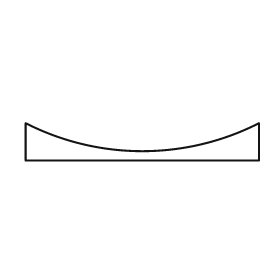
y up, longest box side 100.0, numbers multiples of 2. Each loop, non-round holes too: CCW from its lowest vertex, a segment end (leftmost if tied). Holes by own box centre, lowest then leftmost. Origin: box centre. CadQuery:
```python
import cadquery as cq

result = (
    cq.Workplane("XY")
    .moveTo(-50.0, -8.0)
    .lineTo(50.0, -8.0)
    .lineTo(50.0, 8.0)
    .threePointArc((0.0, -4.0), (-50.0, 8.0))
    .close()
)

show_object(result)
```